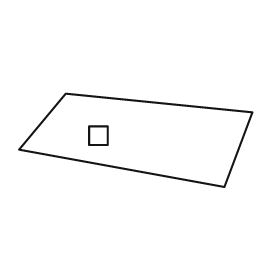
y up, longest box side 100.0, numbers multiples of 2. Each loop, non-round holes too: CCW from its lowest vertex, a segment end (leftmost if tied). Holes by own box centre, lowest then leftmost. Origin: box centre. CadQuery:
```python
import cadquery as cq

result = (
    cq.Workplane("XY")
    .moveTo(38.0, -20.0)
    .lineTo(50.0, 12.0)
    .lineTo(-30.0, 20.0)
    .lineTo(-50.0, -4.0)
    .close()
    .moveTo(-20.0, -2.0)
    .lineTo(-12.0, -2.0)
    .lineTo(-12.0, 6.0)
    .lineTo(-20.0, 6.0)
    .close()
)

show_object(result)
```